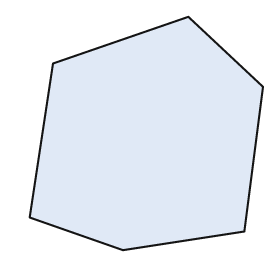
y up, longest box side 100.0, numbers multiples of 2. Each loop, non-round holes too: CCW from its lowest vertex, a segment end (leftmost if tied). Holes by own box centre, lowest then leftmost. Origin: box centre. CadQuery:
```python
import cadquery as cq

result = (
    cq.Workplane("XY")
    .moveTo(-10.0, -50.0)
    .lineTo(42.0, -42.0)
    .lineTo(50.0, 20.0)
    .lineTo(18.0, 50.0)
    .lineTo(-40.0, 30.0)
    .lineTo(-50.0, -36.0)
    .close()
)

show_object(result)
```